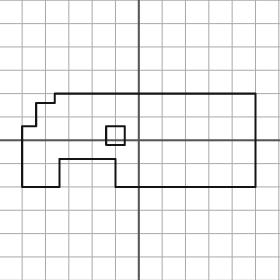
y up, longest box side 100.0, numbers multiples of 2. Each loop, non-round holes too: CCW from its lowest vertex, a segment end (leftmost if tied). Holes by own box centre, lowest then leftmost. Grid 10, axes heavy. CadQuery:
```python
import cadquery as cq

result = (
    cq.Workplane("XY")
    .moveTo(-50.0, -20.0)
    .lineTo(-34.0, -20.0)
    .lineTo(-34.0, -8.0)
    .lineTo(-10.0, -8.0)
    .lineTo(-10.0, -20.0)
    .lineTo(50.0, -20.0)
    .lineTo(50.0, 20.0)
    .lineTo(-36.0, 20.0)
    .lineTo(-36.0, 16.0)
    .lineTo(-44.0, 16.0)
    .lineTo(-44.0, 6.0)
    .lineTo(-50.0, 6.0)
    .close()
    .moveTo(-14.0, -2.0)
    .lineTo(-6.0, -2.0)
    .lineTo(-6.0, 6.0)
    .lineTo(-14.0, 6.0)
    .close()
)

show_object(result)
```